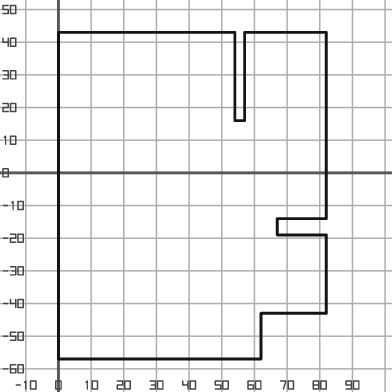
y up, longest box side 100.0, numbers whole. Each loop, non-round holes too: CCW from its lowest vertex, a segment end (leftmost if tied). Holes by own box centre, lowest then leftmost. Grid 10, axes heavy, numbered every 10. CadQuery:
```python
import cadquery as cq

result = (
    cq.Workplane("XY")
    .moveTo(0.0, -57.0)
    .lineTo(62.0, -57.0)
    .lineTo(62.0, -43.0)
    .lineTo(82.0, -43.0)
    .lineTo(82.0, -19.0)
    .lineTo(67.0, -19.0)
    .lineTo(67.0, -14.0)
    .lineTo(82.0, -14.0)
    .lineTo(82.0, 43.0)
    .lineTo(57.0, 43.0)
    .lineTo(57.0, 16.0)
    .lineTo(54.0, 16.0)
    .lineTo(54.0, 43.0)
    .lineTo(0.0, 43.0)
    .close()
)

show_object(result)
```